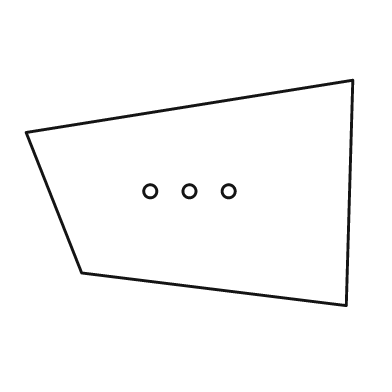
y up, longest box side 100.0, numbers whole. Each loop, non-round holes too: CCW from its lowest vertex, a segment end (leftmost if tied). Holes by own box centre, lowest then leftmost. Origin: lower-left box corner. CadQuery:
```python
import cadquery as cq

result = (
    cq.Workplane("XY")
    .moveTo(98.0, 0.0)
    .lineTo(100.0, 69.0)
    .lineTo(0.0, 53.0)
    .lineTo(17.0, 10.0)
    .close()
    .moveTo(38.0, 35.0)
    .circle(2.0)
    .moveTo(50.0, 35.0)
    .circle(2.0)
    .moveTo(62.0, 35.0)
    .circle(2.0)
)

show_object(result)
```